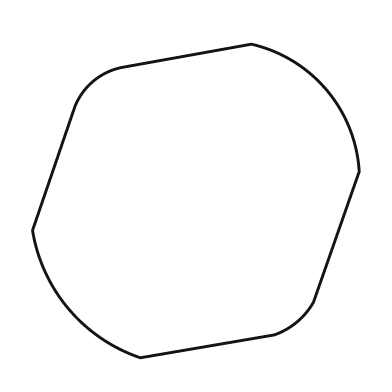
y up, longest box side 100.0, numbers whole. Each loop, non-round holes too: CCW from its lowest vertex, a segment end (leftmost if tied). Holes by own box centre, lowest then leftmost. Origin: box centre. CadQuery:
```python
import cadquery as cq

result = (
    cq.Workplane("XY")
    .moveTo(-17.0, -48.0)
    .lineTo(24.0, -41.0)
    .threePointArc((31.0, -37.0), (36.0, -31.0))
    .lineTo(50.0, 9.0)
    .threePointArc((40.0, 34.0), (17.0, 48.0))
    .lineTo(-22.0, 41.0)
    .threePointArc((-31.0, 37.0), (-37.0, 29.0))
    .lineTo(-50.0, -9.0)
    .threePointArc((-39.0, -33.0), (-17.0, -48.0))
    .close()
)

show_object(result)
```